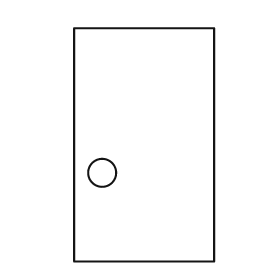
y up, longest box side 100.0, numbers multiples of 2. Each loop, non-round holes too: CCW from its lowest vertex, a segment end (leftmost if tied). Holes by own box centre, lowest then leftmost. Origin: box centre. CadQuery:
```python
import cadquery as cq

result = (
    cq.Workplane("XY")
    .moveTo(-30.0, -50.0)
    .lineTo(30.0, -50.0)
    .lineTo(30.0, 50.0)
    .lineTo(-30.0, 50.0)
    .close()
    .moveTo(-18.0, -12.0)
    .circle(6.0)
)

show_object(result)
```